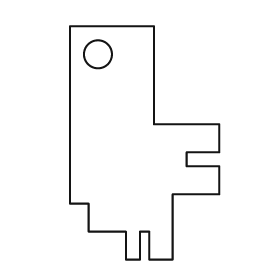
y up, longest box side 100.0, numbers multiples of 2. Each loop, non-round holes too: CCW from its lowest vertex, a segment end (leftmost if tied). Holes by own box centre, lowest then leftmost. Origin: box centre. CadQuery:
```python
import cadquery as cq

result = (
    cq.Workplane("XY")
    .moveTo(-8.0, -50.0)
    .lineTo(-2.0, -50.0)
    .lineTo(-2.0, -38.0)
    .lineTo(2.0, -38.0)
    .lineTo(2.0, -50.0)
    .lineTo(12.0, -50.0)
    .lineTo(12.0, -22.0)
    .lineTo(32.0, -22.0)
    .lineTo(32.0, -10.0)
    .lineTo(18.0, -10.0)
    .lineTo(18.0, -4.0)
    .lineTo(32.0, -4.0)
    .lineTo(32.0, 8.0)
    .lineTo(4.0, 8.0)
    .lineTo(4.0, 50.0)
    .lineTo(-32.0, 50.0)
    .lineTo(-32.0, -26.0)
    .lineTo(-24.0, -26.0)
    .lineTo(-24.0, -38.0)
    .lineTo(-8.0, -38.0)
    .close()
    .moveTo(-20.0, 38.0)
    .circle(6.0)
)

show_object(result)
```